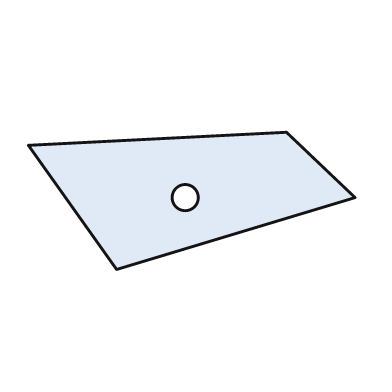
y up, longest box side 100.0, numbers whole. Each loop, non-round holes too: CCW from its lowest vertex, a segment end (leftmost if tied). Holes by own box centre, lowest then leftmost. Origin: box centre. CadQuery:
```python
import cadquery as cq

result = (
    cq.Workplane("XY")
    .moveTo(-23.0, -21.0)
    .lineTo(50.0, 1.0)
    .lineTo(29.0, 21.0)
    .lineTo(-50.0, 17.0)
    .close()
    .moveTo(-2.0, 1.0)
    .circle(4.0)
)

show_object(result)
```